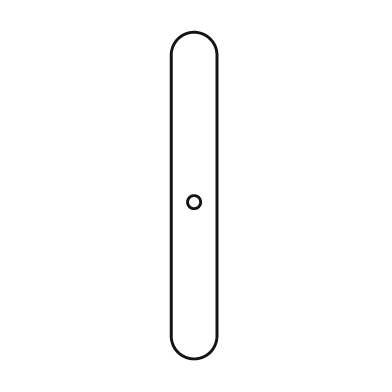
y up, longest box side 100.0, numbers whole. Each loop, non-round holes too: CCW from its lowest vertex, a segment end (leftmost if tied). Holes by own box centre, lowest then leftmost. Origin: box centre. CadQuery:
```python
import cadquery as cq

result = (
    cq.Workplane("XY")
    .moveTo(-7.0, -43.0)
    .threePointArc((0.0, -50.0), (7.0, -43.0))
    .lineTo(7.0, 43.0)
    .threePointArc((0.0, 50.0), (-7.0, 43.0))
    .close()
    .moveTo(0.0, -2.0)
    .circle(2.0)
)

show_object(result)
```